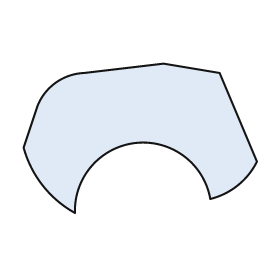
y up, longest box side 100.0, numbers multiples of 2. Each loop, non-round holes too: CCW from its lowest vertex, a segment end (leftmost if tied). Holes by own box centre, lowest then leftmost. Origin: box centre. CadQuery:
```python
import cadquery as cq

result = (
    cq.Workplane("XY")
    .moveTo(-28.0, -32.0)
    .threePointArc((-2.0, -2.0), (30.0, -26.0))
    .threePointArc((42.0, -20.0), (50.0, -10.0))
    .lineTo(34.0, 28.0)
    .lineTo(10.0, 32.0)
    .lineTo(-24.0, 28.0)
    .threePointArc((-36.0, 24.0), (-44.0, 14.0))
    .lineTo(-50.0, -4.0)
    .threePointArc((-42.0, -20.0), (-28.0, -32.0))
    .close()
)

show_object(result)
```